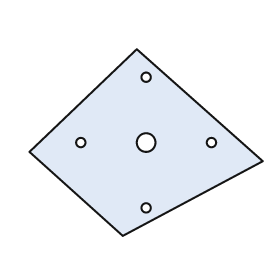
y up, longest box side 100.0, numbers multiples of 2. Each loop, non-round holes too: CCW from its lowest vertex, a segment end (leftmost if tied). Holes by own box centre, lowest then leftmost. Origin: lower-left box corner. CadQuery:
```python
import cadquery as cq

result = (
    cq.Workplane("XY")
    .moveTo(40.0, 0.0)
    .lineTo(100.0, 32.0)
    .lineTo(46.0, 80.0)
    .lineTo(0.0, 36.0)
    .close()
    .moveTo(50.0, 12.0)
    .circle(2.0)
    .moveTo(22.0, 40.0)
    .circle(2.0)
    .moveTo(50.0, 40.0)
    .circle(4.0)
    .moveTo(78.0, 40.0)
    .circle(2.0)
    .moveTo(50.0, 68.0)
    .circle(2.0)
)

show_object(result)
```